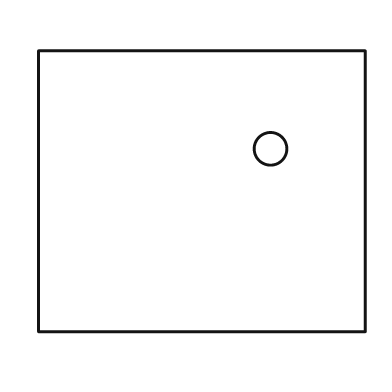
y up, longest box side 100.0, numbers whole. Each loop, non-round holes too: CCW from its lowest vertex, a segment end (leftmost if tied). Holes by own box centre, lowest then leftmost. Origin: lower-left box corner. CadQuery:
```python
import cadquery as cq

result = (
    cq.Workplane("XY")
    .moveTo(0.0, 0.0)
    .lineTo(100.0, 0.0)
    .lineTo(100.0, 86.0)
    .lineTo(0.0, 86.0)
    .close()
    .moveTo(71.0, 56.0)
    .circle(5.0)
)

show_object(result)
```